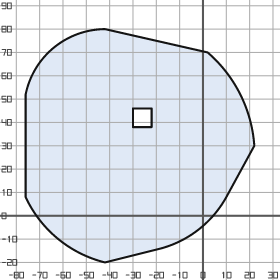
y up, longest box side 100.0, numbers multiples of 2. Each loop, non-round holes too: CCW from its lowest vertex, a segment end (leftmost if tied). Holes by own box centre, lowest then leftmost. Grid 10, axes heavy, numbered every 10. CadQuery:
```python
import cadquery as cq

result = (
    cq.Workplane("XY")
    .moveTo(-42.0, -20.0)
    .lineTo(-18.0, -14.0)
    .threePointArc((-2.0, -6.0), (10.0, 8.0))
    .lineTo(22.0, 30.0)
    .threePointArc((16.0, 52.0), (2.0, 70.0))
    .lineTo(-42.0, 80.0)
    .threePointArc((-64.0, 72.0), (-76.0, 52.0))
    .lineTo(-76.0, 8.0)
    .threePointArc((-62.0, -10.0), (-42.0, -20.0))
    .close()
    .moveTo(-30.0, 38.0)
    .lineTo(-22.0, 38.0)
    .lineTo(-22.0, 46.0)
    .lineTo(-30.0, 46.0)
    .close()
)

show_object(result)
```